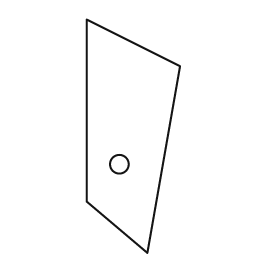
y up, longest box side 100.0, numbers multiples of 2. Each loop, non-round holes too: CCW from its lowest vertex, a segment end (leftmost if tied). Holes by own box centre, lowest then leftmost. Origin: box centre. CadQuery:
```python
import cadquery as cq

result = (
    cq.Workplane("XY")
    .moveTo(6.0, -50.0)
    .lineTo(20.0, 30.0)
    .lineTo(-20.0, 50.0)
    .lineTo(-20.0, -28.0)
    .close()
    .moveTo(-6.0, -12.0)
    .circle(4.0)
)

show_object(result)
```